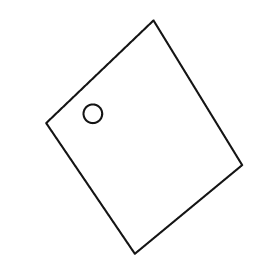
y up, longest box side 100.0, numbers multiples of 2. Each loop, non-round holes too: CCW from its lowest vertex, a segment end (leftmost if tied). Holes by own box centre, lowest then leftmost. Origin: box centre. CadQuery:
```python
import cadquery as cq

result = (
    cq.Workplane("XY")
    .moveTo(-4.0, -50.0)
    .lineTo(42.0, -12.0)
    .lineTo(4.0, 50.0)
    .lineTo(-42.0, 6.0)
    .close()
    .moveTo(-22.0, 10.0)
    .circle(4.0)
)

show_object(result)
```